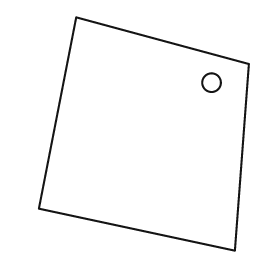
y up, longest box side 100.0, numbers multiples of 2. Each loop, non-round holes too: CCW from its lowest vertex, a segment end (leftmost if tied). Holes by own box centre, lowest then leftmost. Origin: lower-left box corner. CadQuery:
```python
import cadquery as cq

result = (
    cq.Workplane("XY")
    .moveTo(84.0, 0.0)
    .lineTo(90.0, 80.0)
    .lineTo(16.0, 100.0)
    .lineTo(0.0, 18.0)
    .close()
    .moveTo(74.0, 72.0)
    .circle(4.0)
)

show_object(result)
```